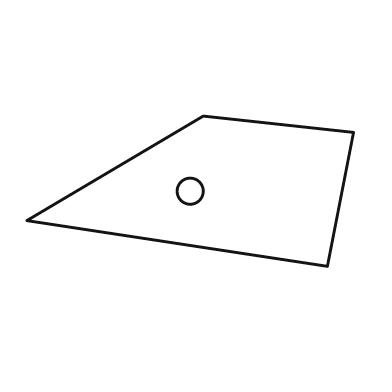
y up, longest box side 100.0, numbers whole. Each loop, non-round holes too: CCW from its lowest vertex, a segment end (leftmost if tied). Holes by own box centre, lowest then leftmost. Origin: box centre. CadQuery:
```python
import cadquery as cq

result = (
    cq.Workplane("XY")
    .moveTo(42.0, -23.0)
    .lineTo(50.0, 18.0)
    .lineTo(4.0, 23.0)
    .lineTo(-50.0, -9.0)
    .close()
    .moveTo(0.0, 0.0)
    .circle(4.0)
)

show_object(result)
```